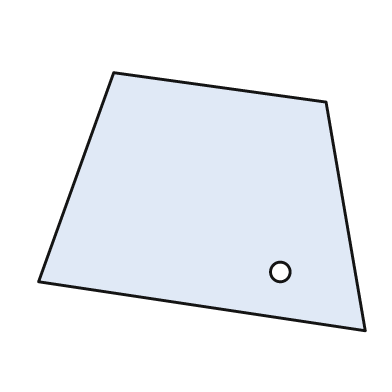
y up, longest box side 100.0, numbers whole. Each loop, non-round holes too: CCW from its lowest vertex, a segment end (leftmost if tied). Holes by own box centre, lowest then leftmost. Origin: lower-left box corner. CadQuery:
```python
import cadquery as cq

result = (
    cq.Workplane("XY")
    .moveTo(100.0, 0.0)
    .lineTo(88.0, 70.0)
    .lineTo(23.0, 79.0)
    .lineTo(0.0, 15.0)
    .close()
    .moveTo(74.0, 18.0)
    .circle(3.0)
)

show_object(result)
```